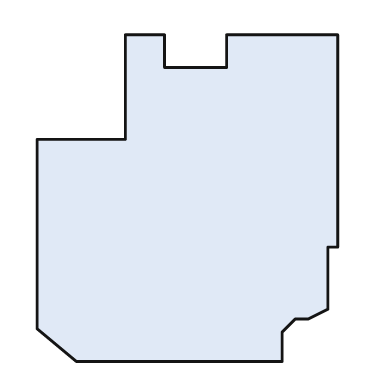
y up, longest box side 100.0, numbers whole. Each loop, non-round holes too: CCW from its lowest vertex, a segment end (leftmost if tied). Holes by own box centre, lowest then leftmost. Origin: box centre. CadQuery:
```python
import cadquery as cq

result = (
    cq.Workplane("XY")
    .moveTo(-34.0, -50.0)
    .lineTo(29.0, -50.0)
    .lineTo(29.0, -41.0)
    .lineTo(33.0, -37.0)
    .lineTo(37.0, -37.0)
    .lineTo(43.0, -34.0)
    .lineTo(43.0, -15.0)
    .lineTo(46.0, -15.0)
    .lineTo(46.0, 50.0)
    .lineTo(12.0, 50.0)
    .lineTo(12.0, 40.0)
    .lineTo(-7.0, 40.0)
    .lineTo(-7.0, 50.0)
    .lineTo(-19.0, 50.0)
    .lineTo(-19.0, 18.0)
    .lineTo(-46.0, 18.0)
    .lineTo(-46.0, -40.0)
    .close()
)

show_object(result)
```